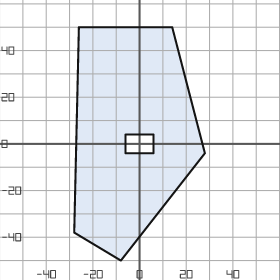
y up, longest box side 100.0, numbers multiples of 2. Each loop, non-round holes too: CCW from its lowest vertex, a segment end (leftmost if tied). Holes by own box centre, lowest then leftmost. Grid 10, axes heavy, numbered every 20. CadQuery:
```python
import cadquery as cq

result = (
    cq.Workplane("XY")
    .moveTo(-8.0, -50.0)
    .lineTo(28.0, -4.0)
    .lineTo(14.0, 50.0)
    .lineTo(-26.0, 50.0)
    .lineTo(-28.0, -38.0)
    .close()
    .moveTo(-6.0, -4.0)
    .lineTo(6.0, -4.0)
    .lineTo(6.0, 4.0)
    .lineTo(-6.0, 4.0)
    .close()
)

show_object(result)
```